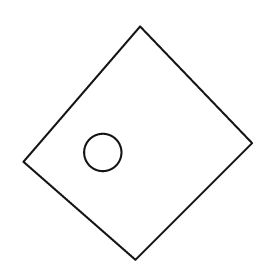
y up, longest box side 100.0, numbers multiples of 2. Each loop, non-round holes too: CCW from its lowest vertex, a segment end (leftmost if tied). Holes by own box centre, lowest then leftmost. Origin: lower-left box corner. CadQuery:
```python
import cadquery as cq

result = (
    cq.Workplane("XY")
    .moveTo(48.0, 0.0)
    .lineTo(98.0, 50.0)
    .lineTo(50.0, 100.0)
    .lineTo(0.0, 42.0)
    .close()
    .moveTo(34.0, 46.0)
    .circle(8.0)
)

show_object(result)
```